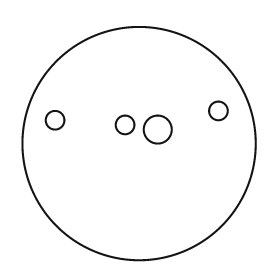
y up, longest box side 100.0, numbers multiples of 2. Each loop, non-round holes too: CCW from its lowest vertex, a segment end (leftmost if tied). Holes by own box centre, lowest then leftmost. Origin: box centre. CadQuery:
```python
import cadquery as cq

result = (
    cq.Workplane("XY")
    .moveTo(0.0, 0.0)
    .circle(50.0)
    .moveTo(8.0, 6.0)
    .circle(6.0)
    .moveTo(-6.0, 8.0)
    .circle(4.0)
    .moveTo(-36.0, 10.0)
    .circle(4.0)
    .moveTo(34.0, 14.0)
    .circle(4.0)
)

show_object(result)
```